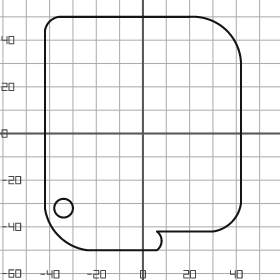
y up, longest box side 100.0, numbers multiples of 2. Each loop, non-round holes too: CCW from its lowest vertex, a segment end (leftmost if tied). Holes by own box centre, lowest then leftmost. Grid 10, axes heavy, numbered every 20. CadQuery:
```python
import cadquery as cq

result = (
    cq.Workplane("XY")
    .moveTo(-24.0, -50.0)
    .lineTo(6.0, -50.0)
    .threePointArc((8.0, -46.0), (6.0, -42.0))
    .lineTo(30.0, -42.0)
    .threePointArc((38.0, -38.0), (42.0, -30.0))
    .lineTo(42.0, 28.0)
    .threePointArc((36.0, 44.0), (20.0, 50.0))
    .lineTo(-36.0, 50.0)
    .threePointArc((-40.0, 48.0), (-42.0, 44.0))
    .lineTo(-42.0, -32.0)
    .threePointArc((-36.0, -44.0), (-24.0, -50.0))
    .close()
    .moveTo(-34.0, -32.0)
    .circle(4.0)
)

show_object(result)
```